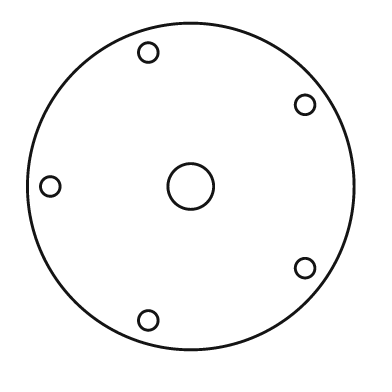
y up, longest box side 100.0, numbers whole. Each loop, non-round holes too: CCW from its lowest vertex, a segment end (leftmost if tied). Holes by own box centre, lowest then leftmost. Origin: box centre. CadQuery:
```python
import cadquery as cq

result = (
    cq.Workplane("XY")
    .moveTo(0.0, 0.0)
    .circle(50.0)
    .moveTo(-13.0, -41.0)
    .circle(3.0)
    .moveTo(35.0, -25.0)
    .circle(3.0)
    .moveTo(-43.0, 0.0)
    .circle(3.0)
    .moveTo(0.0, 0.0)
    .circle(7.0)
    .moveTo(35.0, 25.0)
    .circle(3.0)
    .moveTo(-13.0, 41.0)
    .circle(3.0)
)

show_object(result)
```